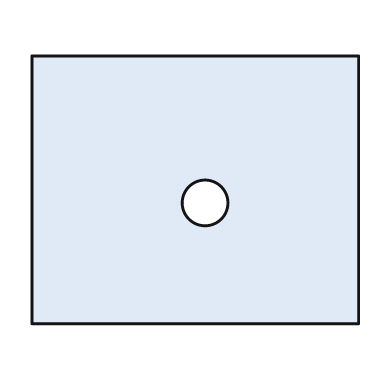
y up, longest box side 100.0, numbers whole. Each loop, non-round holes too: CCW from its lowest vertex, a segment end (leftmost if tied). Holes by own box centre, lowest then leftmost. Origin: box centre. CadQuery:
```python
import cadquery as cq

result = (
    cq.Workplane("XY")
    .moveTo(-50.0, -41.0)
    .lineTo(50.0, -41.0)
    .lineTo(50.0, 41.0)
    .lineTo(-50.0, 41.0)
    .close()
    .moveTo(3.0, -4.0)
    .circle(7.0)
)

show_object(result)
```